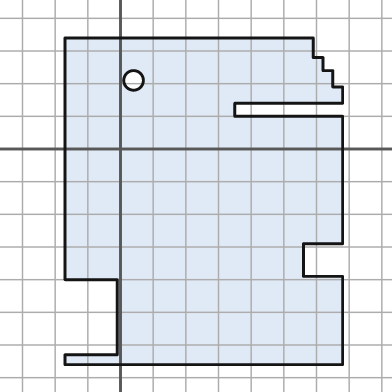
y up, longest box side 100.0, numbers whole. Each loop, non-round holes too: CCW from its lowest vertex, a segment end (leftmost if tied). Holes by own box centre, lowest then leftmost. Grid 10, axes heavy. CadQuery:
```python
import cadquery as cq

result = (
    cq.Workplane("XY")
    .moveTo(-17.0, -66.0)
    .lineTo(68.0, -66.0)
    .lineTo(68.0, -39.0)
    .lineTo(56.0, -39.0)
    .lineTo(56.0, -29.0)
    .lineTo(68.0, -29.0)
    .lineTo(68.0, 10.0)
    .lineTo(35.0, 10.0)
    .lineTo(35.0, 14.0)
    .lineTo(68.0, 14.0)
    .lineTo(68.0, 19.0)
    .lineTo(65.0, 19.0)
    .lineTo(65.0, 24.0)
    .lineTo(62.0, 24.0)
    .lineTo(62.0, 28.0)
    .lineTo(59.0, 28.0)
    .lineTo(59.0, 34.0)
    .lineTo(-17.0, 34.0)
    .lineTo(-17.0, -40.0)
    .lineTo(-1.0, -40.0)
    .lineTo(-1.0, -63.0)
    .lineTo(-17.0, -63.0)
    .close()
    .moveTo(4.0, 21.0)
    .circle(3.0)
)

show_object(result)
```